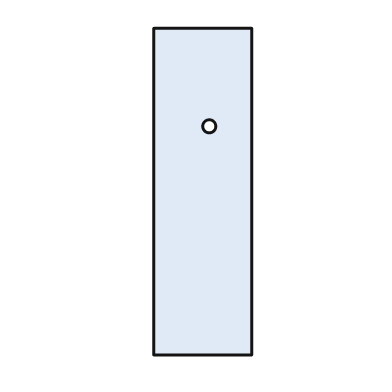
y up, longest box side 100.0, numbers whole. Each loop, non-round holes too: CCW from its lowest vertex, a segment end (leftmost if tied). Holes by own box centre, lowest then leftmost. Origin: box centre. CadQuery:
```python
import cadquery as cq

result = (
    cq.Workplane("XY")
    .moveTo(-15.0, -50.0)
    .lineTo(15.0, -50.0)
    .lineTo(15.0, 50.0)
    .lineTo(-15.0, 50.0)
    .close()
    .moveTo(2.0, 20.0)
    .circle(2.0)
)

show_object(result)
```